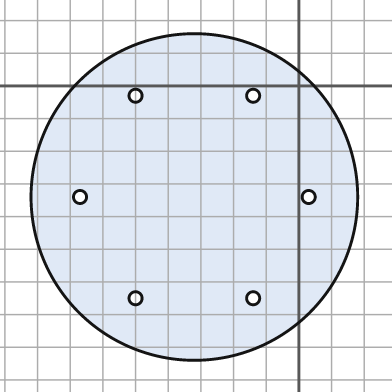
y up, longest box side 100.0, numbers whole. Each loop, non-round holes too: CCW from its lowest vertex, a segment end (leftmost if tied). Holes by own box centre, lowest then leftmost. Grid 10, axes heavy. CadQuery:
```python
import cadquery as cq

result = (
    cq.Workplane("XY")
    .moveTo(-32.0, -34.0)
    .circle(50.0)
    .moveTo(-50.0, -65.0)
    .circle(2.0)
    .moveTo(-14.0, -65.0)
    .circle(2.0)
    .moveTo(-67.0, -34.0)
    .circle(2.0)
    .moveTo(3.0, -34.0)
    .circle(2.0)
    .moveTo(-50.0, -3.0)
    .circle(2.0)
    .moveTo(-14.0, -3.0)
    .circle(2.0)
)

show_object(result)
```